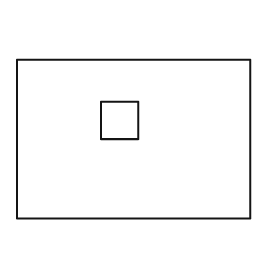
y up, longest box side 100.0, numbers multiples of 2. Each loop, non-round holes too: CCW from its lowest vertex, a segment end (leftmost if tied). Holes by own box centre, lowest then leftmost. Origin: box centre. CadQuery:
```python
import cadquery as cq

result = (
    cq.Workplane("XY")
    .moveTo(-50.0, -34.0)
    .lineTo(50.0, -34.0)
    .lineTo(50.0, 34.0)
    .lineTo(-50.0, 34.0)
    .close()
    .moveTo(-14.0, 0.0)
    .lineTo(2.0, 0.0)
    .lineTo(2.0, 16.0)
    .lineTo(-14.0, 16.0)
    .close()
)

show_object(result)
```